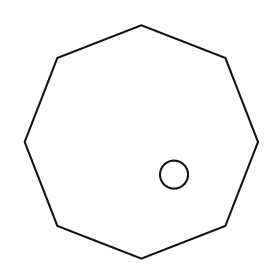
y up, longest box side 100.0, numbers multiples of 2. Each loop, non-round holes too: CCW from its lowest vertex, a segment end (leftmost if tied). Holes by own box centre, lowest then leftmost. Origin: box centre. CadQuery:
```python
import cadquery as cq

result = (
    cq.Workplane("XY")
    .moveTo(0.0, -50.0)
    .lineTo(36.0, -36.0)
    .lineTo(50.0, 0.0)
    .lineTo(36.0, 36.0)
    .lineTo(0.0, 50.0)
    .lineTo(-36.0, 36.0)
    .lineTo(-50.0, 0.0)
    .lineTo(-36.0, -36.0)
    .close()
    .moveTo(14.0, -14.0)
    .circle(6.0)
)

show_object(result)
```